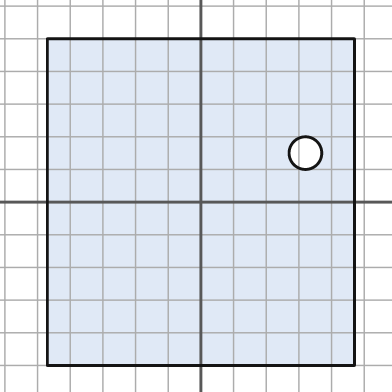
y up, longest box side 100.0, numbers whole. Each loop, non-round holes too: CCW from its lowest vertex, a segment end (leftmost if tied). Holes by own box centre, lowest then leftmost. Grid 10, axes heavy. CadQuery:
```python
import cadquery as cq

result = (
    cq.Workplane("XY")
    .moveTo(-47.0, -50.0)
    .lineTo(47.0, -50.0)
    .lineTo(47.0, 50.0)
    .lineTo(-47.0, 50.0)
    .close()
    .moveTo(32.0, 15.0)
    .circle(5.0)
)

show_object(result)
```